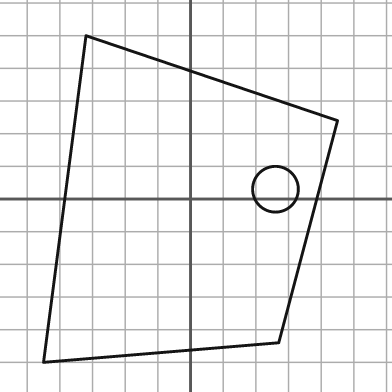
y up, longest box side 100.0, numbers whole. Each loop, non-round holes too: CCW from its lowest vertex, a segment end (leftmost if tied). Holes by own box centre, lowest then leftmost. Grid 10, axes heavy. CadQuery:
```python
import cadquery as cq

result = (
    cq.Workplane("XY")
    .moveTo(-45.0, -50.0)
    .lineTo(27.0, -44.0)
    .lineTo(45.0, 24.0)
    .lineTo(-32.0, 50.0)
    .close()
    .moveTo(26.0, 3.0)
    .circle(7.0)
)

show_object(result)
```